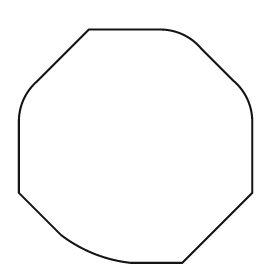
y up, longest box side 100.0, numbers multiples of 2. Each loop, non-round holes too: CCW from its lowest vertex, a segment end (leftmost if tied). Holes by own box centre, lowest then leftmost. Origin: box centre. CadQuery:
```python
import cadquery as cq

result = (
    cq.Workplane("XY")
    .moveTo(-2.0, -50.0)
    .lineTo(20.0, -50.0)
    .lineTo(50.0, -20.0)
    .lineTo(50.0, 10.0)
    .threePointArc((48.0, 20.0), (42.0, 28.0))
    .lineTo(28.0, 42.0)
    .threePointArc((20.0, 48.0), (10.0, 50.0))
    .lineTo(-20.0, 50.0)
    .lineTo(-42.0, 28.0)
    .threePointArc((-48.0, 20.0), (-50.0, 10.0))
    .lineTo(-50.0, -20.0)
    .lineTo(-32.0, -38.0)
    .threePointArc((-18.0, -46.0), (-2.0, -50.0))
    .close()
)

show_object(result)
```